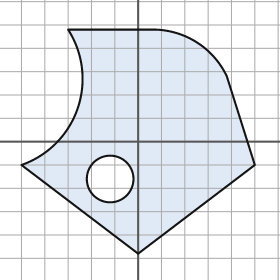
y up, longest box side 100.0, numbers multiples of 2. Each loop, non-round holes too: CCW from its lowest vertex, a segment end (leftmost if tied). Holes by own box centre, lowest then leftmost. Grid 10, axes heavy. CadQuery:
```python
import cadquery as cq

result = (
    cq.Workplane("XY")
    .moveTo(0.0, -48.0)
    .lineTo(50.0, -10.0)
    .lineTo(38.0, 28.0)
    .threePointArc((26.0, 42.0), (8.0, 48.0))
    .lineTo(-30.0, 48.0)
    .threePointArc((-26.0, 14.0), (-50.0, -10.0))
    .close()
    .moveTo(-12.0, -16.0)
    .circle(10.0)
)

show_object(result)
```